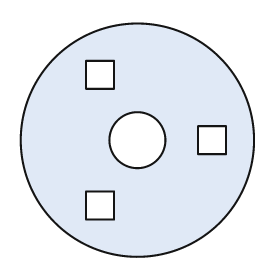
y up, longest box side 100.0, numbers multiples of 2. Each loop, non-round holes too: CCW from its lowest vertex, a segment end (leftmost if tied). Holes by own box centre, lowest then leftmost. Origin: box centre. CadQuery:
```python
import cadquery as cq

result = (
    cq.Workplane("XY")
    .moveTo(0.0, 0.0)
    .circle(50.0)
    .moveTo(-22.0, -34.0)
    .lineTo(-10.0, -34.0)
    .lineTo(-10.0, -22.0)
    .lineTo(-22.0, -22.0)
    .close()
    .moveTo(0.0, 0.0)
    .circle(12.0)
    .moveTo(26.0, -6.0)
    .lineTo(38.0, -6.0)
    .lineTo(38.0, 6.0)
    .lineTo(26.0, 6.0)
    .close()
    .moveTo(-22.0, 22.0)
    .lineTo(-10.0, 22.0)
    .lineTo(-10.0, 34.0)
    .lineTo(-22.0, 34.0)
    .close()
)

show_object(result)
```